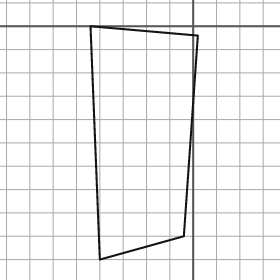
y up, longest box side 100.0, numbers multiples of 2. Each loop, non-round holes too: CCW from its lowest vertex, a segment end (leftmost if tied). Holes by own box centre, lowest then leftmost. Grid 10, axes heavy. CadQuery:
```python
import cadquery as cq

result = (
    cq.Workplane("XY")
    .moveTo(-40.0, -100.0)
    .lineTo(-4.0, -90.0)
    .lineTo(2.0, -4.0)
    .lineTo(-44.0, 0.0)
    .close()
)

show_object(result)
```